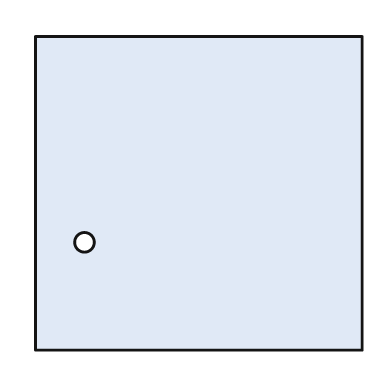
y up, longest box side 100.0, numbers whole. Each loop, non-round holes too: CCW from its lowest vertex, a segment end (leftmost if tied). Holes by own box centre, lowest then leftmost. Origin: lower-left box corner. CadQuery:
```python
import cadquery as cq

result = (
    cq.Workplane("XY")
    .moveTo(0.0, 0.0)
    .lineTo(100.0, 0.0)
    .lineTo(100.0, 96.0)
    .lineTo(0.0, 96.0)
    .close()
    .moveTo(15.0, 33.0)
    .circle(3.0)
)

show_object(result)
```